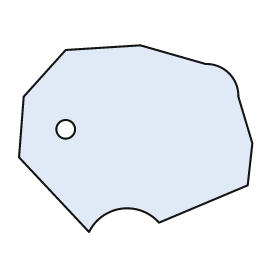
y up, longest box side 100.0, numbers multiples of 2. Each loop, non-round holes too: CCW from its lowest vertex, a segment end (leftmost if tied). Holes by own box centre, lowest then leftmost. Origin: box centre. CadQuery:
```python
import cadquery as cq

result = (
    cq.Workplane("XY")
    .moveTo(-20.0, -40.0)
    .threePointArc((-6.0, -30.0), (10.0, -36.0))
    .lineTo(48.0, -20.0)
    .lineTo(50.0, -2.0)
    .lineTo(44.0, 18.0)
    .threePointArc((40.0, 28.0), (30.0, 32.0))
    .lineTo(2.0, 40.0)
    .lineTo(-30.0, 38.0)
    .lineTo(-48.0, 18.0)
    .lineTo(-50.0, -8.0)
    .close()
    .moveTo(-30.0, 4.0)
    .circle(4.0)
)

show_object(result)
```